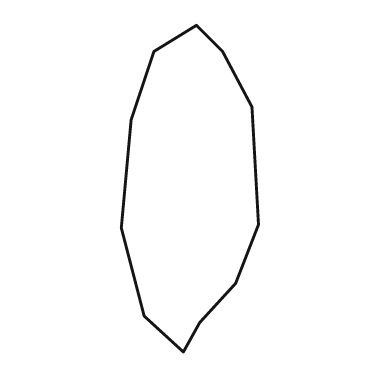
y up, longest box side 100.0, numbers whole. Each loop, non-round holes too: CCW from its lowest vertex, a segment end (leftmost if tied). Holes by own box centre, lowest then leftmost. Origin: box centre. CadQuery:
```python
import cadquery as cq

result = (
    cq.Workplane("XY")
    .moveTo(-2.0, -50.0)
    .lineTo(3.0, -41.0)
    .lineTo(14.0, -29.0)
    .lineTo(21.0, -11.0)
    .lineTo(19.0, 25.0)
    .lineTo(10.0, 42.0)
    .lineTo(2.0, 50.0)
    .lineTo(-11.0, 42.0)
    .lineTo(-18.0, 21.0)
    .lineTo(-21.0, -12.0)
    .lineTo(-14.0, -39.0)
    .close()
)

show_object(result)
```